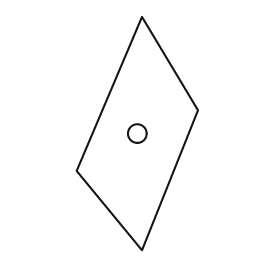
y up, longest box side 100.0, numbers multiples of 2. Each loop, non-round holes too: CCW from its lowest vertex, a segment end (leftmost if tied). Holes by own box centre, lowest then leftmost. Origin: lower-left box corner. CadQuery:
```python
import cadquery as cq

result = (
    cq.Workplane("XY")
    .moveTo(28.0, 0.0)
    .lineTo(52.0, 60.0)
    .lineTo(28.0, 100.0)
    .lineTo(0.0, 34.0)
    .close()
    .moveTo(26.0, 50.0)
    .circle(4.0)
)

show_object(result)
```